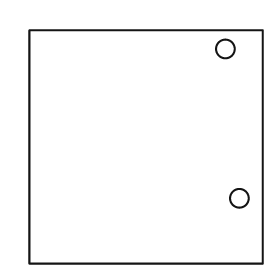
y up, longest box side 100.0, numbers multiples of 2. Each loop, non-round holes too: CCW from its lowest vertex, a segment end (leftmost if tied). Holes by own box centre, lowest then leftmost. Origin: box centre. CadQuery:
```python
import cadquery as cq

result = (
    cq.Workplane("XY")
    .moveTo(-50.0, -50.0)
    .lineTo(50.0, -50.0)
    .lineTo(50.0, 50.0)
    .lineTo(-50.0, 50.0)
    .close()
    .moveTo(40.0, -22.0)
    .circle(4.0)
    .moveTo(34.0, 42.0)
    .circle(4.0)
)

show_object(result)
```